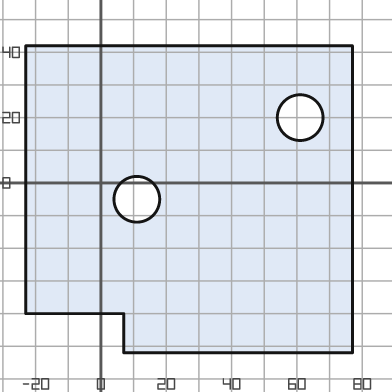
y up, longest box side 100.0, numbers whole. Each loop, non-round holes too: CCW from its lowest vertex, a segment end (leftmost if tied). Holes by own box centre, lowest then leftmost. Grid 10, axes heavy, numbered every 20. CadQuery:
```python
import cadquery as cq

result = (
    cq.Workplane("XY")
    .moveTo(7.0, -52.0)
    .lineTo(77.0, -52.0)
    .lineTo(77.0, 42.0)
    .lineTo(-23.0, 42.0)
    .lineTo(-23.0, -40.0)
    .lineTo(7.0, -40.0)
    .close()
    .moveTo(11.0, -5.0)
    .circle(7.0)
    .moveTo(61.0, 20.0)
    .circle(7.0)
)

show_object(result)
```